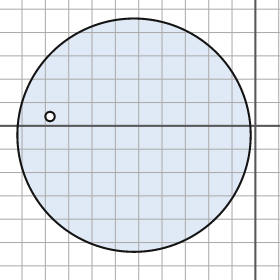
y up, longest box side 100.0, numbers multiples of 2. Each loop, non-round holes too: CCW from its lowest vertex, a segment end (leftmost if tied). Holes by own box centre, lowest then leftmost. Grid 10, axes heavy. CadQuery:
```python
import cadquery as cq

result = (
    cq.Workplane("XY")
    .moveTo(-52.0, -4.0)
    .circle(50.0)
    .moveTo(-88.0, 4.0)
    .circle(2.0)
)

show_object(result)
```